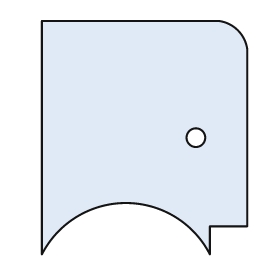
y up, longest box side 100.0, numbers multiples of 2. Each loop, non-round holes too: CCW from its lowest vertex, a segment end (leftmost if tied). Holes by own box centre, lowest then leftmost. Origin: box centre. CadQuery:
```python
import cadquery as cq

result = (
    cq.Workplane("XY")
    .moveTo(-44.0, -50.0)
    .threePointArc((-8.0, -28.0), (28.0, -50.0))
    .lineTo(28.0, -38.0)
    .lineTo(44.0, -38.0)
    .lineTo(44.0, 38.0)
    .threePointArc((40.0, 46.0), (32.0, 50.0))
    .lineTo(-44.0, 50.0)
    .close()
    .moveTo(22.0, 0.0)
    .circle(4.0)
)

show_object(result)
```